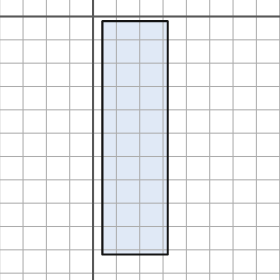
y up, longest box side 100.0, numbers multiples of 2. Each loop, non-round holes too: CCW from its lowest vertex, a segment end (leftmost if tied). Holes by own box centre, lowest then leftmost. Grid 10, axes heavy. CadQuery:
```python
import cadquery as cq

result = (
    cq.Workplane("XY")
    .moveTo(4.0, -102.0)
    .lineTo(32.0, -102.0)
    .lineTo(32.0, -2.0)
    .lineTo(4.0, -2.0)
    .close()
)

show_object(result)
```